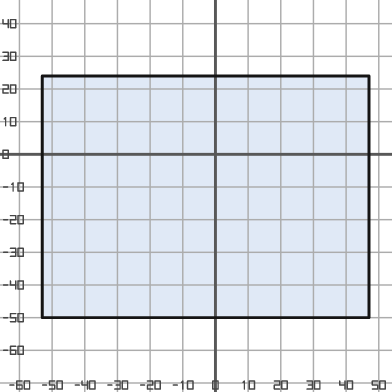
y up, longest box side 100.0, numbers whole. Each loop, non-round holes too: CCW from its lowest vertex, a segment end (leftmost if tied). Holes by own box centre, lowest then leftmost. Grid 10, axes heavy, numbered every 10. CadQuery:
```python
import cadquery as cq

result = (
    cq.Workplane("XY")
    .moveTo(-53.0, -50.0)
    .lineTo(47.0, -50.0)
    .lineTo(47.0, 24.0)
    .lineTo(-53.0, 24.0)
    .close()
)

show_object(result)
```